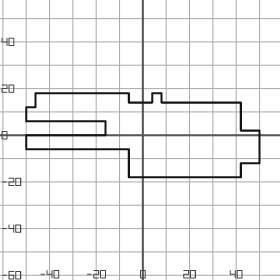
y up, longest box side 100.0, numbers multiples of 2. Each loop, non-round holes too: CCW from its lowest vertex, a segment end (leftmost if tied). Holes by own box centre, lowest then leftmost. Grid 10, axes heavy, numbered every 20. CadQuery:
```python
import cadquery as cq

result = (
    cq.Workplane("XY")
    .moveTo(-6.0, -18.0)
    .lineTo(42.0, -18.0)
    .lineTo(42.0, -12.0)
    .lineTo(50.0, -12.0)
    .lineTo(50.0, 2.0)
    .lineTo(42.0, 2.0)
    .lineTo(42.0, 14.0)
    .lineTo(8.0, 14.0)
    .lineTo(8.0, 18.0)
    .lineTo(4.0, 18.0)
    .lineTo(4.0, 14.0)
    .lineTo(-6.0, 14.0)
    .lineTo(-6.0, 18.0)
    .lineTo(-46.0, 18.0)
    .lineTo(-46.0, 12.0)
    .lineTo(-50.0, 12.0)
    .lineTo(-50.0, 6.0)
    .lineTo(-16.0, 6.0)
    .lineTo(-16.0, 0.0)
    .lineTo(-50.0, 0.0)
    .lineTo(-50.0, -6.0)
    .lineTo(-6.0, -6.0)
    .close()
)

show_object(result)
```